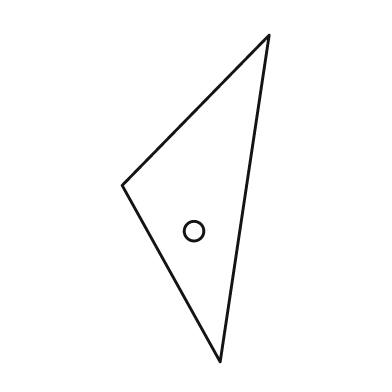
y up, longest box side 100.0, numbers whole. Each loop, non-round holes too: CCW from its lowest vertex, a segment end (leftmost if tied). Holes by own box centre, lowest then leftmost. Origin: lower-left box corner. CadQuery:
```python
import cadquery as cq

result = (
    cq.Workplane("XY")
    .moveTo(30.0, 0.0)
    .lineTo(45.0, 100.0)
    .lineTo(0.0, 54.0)
    .close()
    .moveTo(22.0, 40.0)
    .circle(3.0)
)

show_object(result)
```